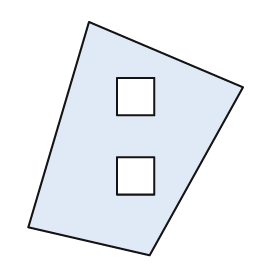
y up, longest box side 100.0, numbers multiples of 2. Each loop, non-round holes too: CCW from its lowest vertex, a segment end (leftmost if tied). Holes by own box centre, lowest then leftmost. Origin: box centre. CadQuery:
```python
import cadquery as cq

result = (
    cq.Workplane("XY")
    .moveTo(6.0, -50.0)
    .lineTo(46.0, 22.0)
    .lineTo(-20.0, 50.0)
    .lineTo(-46.0, -38.0)
    .close()
    .moveTo(-8.0, -24.0)
    .lineTo(8.0, -24.0)
    .lineTo(8.0, -8.0)
    .lineTo(-8.0, -8.0)
    .close()
    .moveTo(-8.0, 10.0)
    .lineTo(8.0, 10.0)
    .lineTo(8.0, 26.0)
    .lineTo(-8.0, 26.0)
    .close()
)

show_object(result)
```